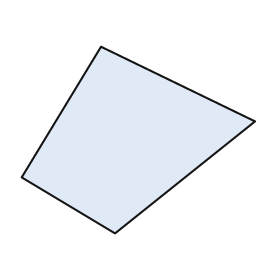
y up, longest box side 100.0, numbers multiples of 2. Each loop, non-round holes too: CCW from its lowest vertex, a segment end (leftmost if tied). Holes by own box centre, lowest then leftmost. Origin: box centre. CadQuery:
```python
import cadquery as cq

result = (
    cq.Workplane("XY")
    .moveTo(-10.0, -40.0)
    .lineTo(50.0, 8.0)
    .lineTo(-16.0, 40.0)
    .lineTo(-50.0, -16.0)
    .close()
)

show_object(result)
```